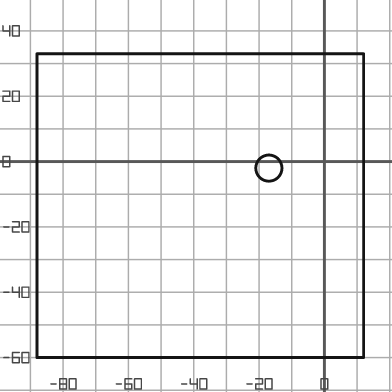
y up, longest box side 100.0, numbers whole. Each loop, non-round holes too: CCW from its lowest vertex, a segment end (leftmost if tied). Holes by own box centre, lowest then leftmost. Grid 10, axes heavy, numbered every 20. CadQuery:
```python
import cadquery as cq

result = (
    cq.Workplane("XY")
    .moveTo(-88.0, -60.0)
    .lineTo(12.0, -60.0)
    .lineTo(12.0, 33.0)
    .lineTo(-88.0, 33.0)
    .close()
    .moveTo(-17.0, -2.0)
    .circle(4.0)
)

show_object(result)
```